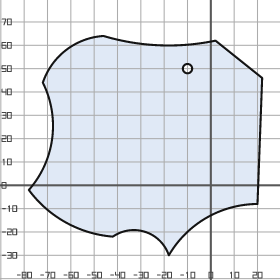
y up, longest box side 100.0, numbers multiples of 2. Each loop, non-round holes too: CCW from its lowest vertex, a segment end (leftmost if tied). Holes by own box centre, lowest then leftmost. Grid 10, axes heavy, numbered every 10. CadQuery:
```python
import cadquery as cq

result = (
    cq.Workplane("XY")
    .moveTo(-18.0, -30.0)
    .threePointArc((-2.0, -14.0), (20.0, -8.0))
    .lineTo(22.0, 46.0)
    .lineTo(2.0, 62.0)
    .threePointArc((-22.0, 60.0), (-46.0, 64.0))
    .threePointArc((-62.0, 58.0), (-72.0, 44.0))
    .threePointArc((-68.0, 20.0), (-78.0, -2.0))
    .threePointArc((-62.0, -16.0), (-42.0, -22.0))
    .threePointArc((-28.0, -20.0), (-18.0, -30.0))
    .close()
    .moveTo(-10.0, 50.0)
    .circle(2.0)
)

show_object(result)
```